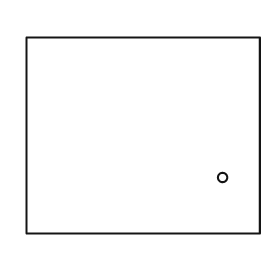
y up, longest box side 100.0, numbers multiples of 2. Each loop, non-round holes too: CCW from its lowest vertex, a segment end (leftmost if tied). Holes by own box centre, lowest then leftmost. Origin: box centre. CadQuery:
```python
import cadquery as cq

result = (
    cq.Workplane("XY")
    .moveTo(-50.0, -42.0)
    .lineTo(50.0, -42.0)
    .lineTo(50.0, 42.0)
    .lineTo(-50.0, 42.0)
    .close()
    .moveTo(34.0, -18.0)
    .circle(2.0)
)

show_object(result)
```